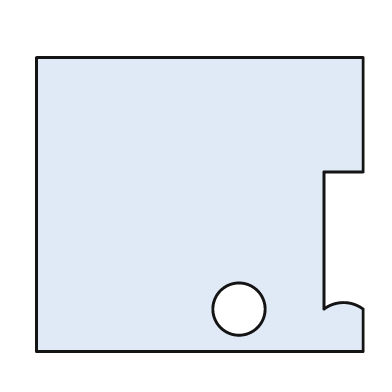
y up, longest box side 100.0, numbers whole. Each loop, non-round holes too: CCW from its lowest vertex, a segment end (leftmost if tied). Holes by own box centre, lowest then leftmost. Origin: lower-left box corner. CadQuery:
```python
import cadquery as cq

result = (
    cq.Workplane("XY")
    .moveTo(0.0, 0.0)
    .lineTo(100.0, 0.0)
    .lineTo(100.0, 13.0)
    .threePointArc((94.0, 15.0), (88.0, 13.0))
    .lineTo(88.0, 55.0)
    .lineTo(100.0, 55.0)
    .lineTo(100.0, 90.0)
    .lineTo(0.0, 90.0)
    .close()
    .moveTo(62.0, 13.0)
    .circle(8.0)
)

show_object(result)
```